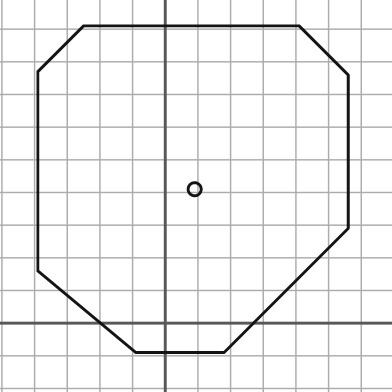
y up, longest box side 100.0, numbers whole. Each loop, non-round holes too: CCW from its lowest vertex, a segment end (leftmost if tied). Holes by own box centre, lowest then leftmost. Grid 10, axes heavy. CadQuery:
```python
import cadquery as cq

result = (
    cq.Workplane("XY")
    .moveTo(-9.0, -9.0)
    .lineTo(18.0, -9.0)
    .lineTo(56.0, 29.0)
    .lineTo(56.0, 76.0)
    .lineTo(41.0, 91.0)
    .lineTo(-25.0, 91.0)
    .lineTo(-39.0, 77.0)
    .lineTo(-39.0, 16.0)
    .close()
    .moveTo(9.0, 41.0)
    .circle(2.0)
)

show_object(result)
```